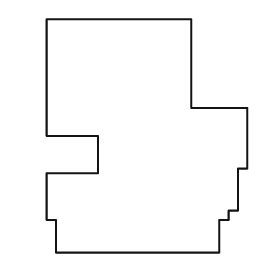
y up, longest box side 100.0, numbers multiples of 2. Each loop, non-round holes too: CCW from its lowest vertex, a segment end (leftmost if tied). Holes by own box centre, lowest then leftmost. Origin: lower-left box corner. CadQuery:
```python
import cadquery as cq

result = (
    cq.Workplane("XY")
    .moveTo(4.0, 0.0)
    .lineTo(74.0, 0.0)
    .lineTo(74.0, 14.0)
    .lineTo(78.0, 14.0)
    .lineTo(78.0, 18.0)
    .lineTo(82.0, 18.0)
    .lineTo(82.0, 36.0)
    .lineTo(86.0, 36.0)
    .lineTo(86.0, 62.0)
    .lineTo(62.0, 62.0)
    .lineTo(62.0, 100.0)
    .lineTo(0.0, 100.0)
    .lineTo(0.0, 50.0)
    .lineTo(22.0, 50.0)
    .lineTo(22.0, 34.0)
    .lineTo(0.0, 34.0)
    .lineTo(0.0, 14.0)
    .lineTo(4.0, 14.0)
    .close()
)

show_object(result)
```